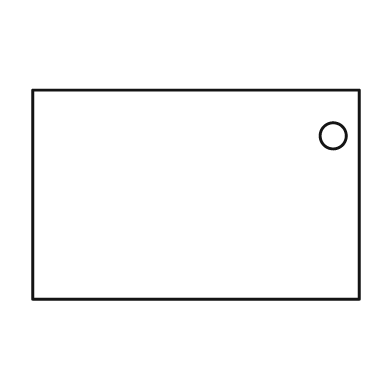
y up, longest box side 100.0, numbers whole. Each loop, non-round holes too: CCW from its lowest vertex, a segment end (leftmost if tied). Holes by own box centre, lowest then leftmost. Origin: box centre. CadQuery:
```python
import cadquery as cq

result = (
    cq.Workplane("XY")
    .moveTo(-50.0, -32.0)
    .lineTo(50.0, -32.0)
    .lineTo(50.0, 32.0)
    .lineTo(-50.0, 32.0)
    .close()
    .moveTo(42.0, 18.0)
    .circle(4.0)
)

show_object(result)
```